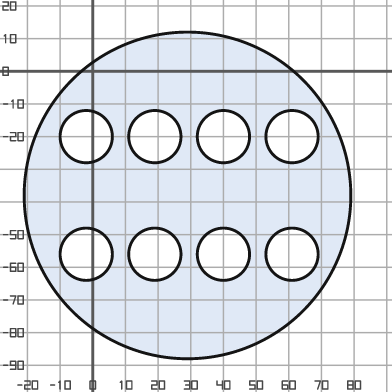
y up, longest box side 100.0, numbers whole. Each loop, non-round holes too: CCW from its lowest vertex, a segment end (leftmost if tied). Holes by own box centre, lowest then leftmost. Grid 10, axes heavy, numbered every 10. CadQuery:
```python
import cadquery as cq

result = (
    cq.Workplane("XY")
    .moveTo(29.0, -38.0)
    .circle(50.0)
    .moveTo(-2.0, -56.0)
    .circle(8.0)
    .moveTo(19.0, -56.0)
    .circle(8.0)
    .moveTo(40.0, -56.0)
    .circle(8.0)
    .moveTo(61.0, -56.0)
    .circle(8.0)
    .moveTo(-2.0, -20.0)
    .circle(8.0)
    .moveTo(19.0, -20.0)
    .circle(8.0)
    .moveTo(40.0, -20.0)
    .circle(8.0)
    .moveTo(61.0, -20.0)
    .circle(8.0)
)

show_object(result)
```